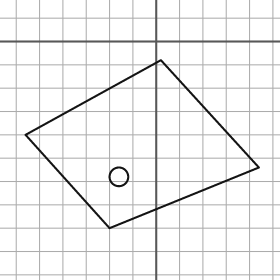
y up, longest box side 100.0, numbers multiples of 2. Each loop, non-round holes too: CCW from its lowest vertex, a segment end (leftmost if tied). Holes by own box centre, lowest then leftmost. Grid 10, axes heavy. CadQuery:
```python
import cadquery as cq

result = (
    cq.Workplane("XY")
    .moveTo(-20.0, -80.0)
    .lineTo(44.0, -54.0)
    .lineTo(2.0, -8.0)
    .lineTo(-56.0, -40.0)
    .close()
    .moveTo(-16.0, -58.0)
    .circle(4.0)
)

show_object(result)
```